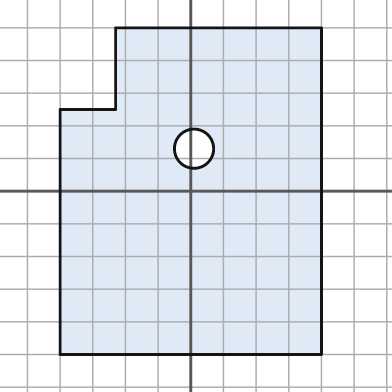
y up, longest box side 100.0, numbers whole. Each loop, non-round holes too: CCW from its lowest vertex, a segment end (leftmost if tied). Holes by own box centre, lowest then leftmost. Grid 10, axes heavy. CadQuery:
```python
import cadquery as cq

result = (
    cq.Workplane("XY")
    .moveTo(-40.0, -50.0)
    .lineTo(40.0, -50.0)
    .lineTo(40.0, 50.0)
    .lineTo(-23.0, 50.0)
    .lineTo(-23.0, 25.0)
    .lineTo(-40.0, 25.0)
    .close()
    .moveTo(1.0, 13.0)
    .circle(6.0)
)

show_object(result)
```